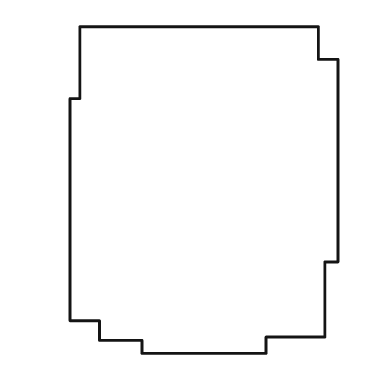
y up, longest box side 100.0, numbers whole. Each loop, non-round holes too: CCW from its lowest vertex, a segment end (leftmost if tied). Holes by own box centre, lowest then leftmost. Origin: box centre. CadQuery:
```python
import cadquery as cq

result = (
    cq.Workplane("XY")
    .moveTo(-19.0, -50.0)
    .lineTo(19.0, -50.0)
    .lineTo(19.0, -45.0)
    .lineTo(37.0, -45.0)
    .lineTo(37.0, -22.0)
    .lineTo(41.0, -22.0)
    .lineTo(41.0, 40.0)
    .lineTo(35.0, 40.0)
    .lineTo(35.0, 50.0)
    .lineTo(-38.0, 50.0)
    .lineTo(-38.0, 28.0)
    .lineTo(-41.0, 28.0)
    .lineTo(-41.0, -40.0)
    .lineTo(-32.0, -40.0)
    .lineTo(-32.0, -46.0)
    .lineTo(-19.0, -46.0)
    .close()
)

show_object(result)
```